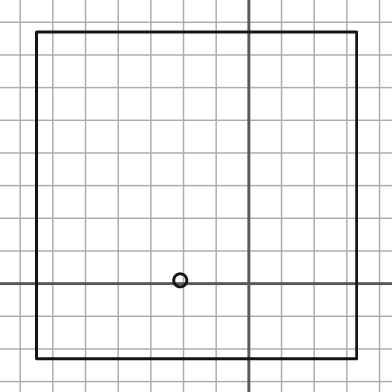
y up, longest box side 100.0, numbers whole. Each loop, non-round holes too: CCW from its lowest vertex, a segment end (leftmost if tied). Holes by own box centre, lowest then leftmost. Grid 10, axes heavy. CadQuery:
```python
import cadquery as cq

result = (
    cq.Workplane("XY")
    .moveTo(-65.0, -23.0)
    .lineTo(33.0, -23.0)
    .lineTo(33.0, 77.0)
    .lineTo(-65.0, 77.0)
    .close()
    .moveTo(-21.0, 1.0)
    .circle(2.0)
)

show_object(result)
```